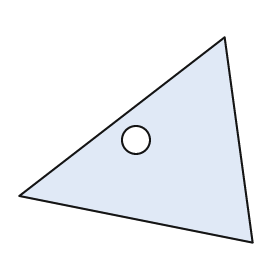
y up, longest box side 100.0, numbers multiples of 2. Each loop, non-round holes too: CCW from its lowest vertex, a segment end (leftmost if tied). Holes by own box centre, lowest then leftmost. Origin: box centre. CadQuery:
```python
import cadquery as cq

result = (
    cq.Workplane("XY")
    .moveTo(50.0, -44.0)
    .lineTo(38.0, 44.0)
    .lineTo(-50.0, -24.0)
    .close()
    .moveTo(0.0, 0.0)
    .circle(6.0)
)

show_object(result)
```